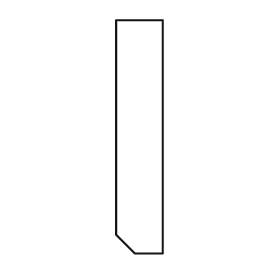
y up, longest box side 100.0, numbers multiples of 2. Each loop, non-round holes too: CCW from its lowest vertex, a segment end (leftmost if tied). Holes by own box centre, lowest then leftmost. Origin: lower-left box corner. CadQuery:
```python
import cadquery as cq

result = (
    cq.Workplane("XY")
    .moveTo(8.0, 0.0)
    .lineTo(20.0, 0.0)
    .lineTo(20.0, 100.0)
    .lineTo(0.0, 100.0)
    .lineTo(0.0, 8.0)
    .close()
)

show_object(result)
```